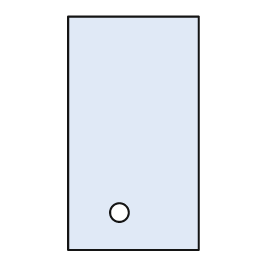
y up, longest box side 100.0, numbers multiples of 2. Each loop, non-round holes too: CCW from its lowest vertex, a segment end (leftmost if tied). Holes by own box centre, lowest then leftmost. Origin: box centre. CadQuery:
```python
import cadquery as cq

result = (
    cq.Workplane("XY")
    .moveTo(-28.0, -50.0)
    .lineTo(28.0, -50.0)
    .lineTo(28.0, 50.0)
    .lineTo(-28.0, 50.0)
    .close()
    .moveTo(-6.0, -34.0)
    .circle(4.0)
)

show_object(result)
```